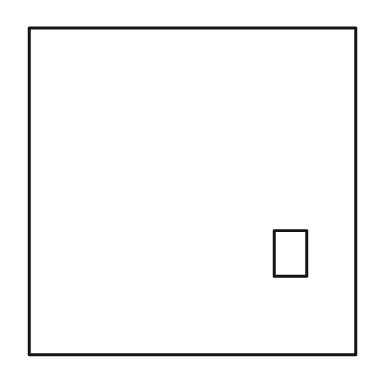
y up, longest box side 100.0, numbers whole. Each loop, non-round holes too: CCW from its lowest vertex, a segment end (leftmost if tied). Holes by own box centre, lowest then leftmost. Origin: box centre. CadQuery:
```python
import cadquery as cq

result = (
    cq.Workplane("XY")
    .moveTo(-50.0, -50.0)
    .lineTo(50.0, -50.0)
    .lineTo(50.0, 50.0)
    .lineTo(-50.0, 50.0)
    .close()
    .moveTo(25.0, -26.0)
    .lineTo(35.0, -26.0)
    .lineTo(35.0, -12.0)
    .lineTo(25.0, -12.0)
    .close()
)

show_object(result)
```